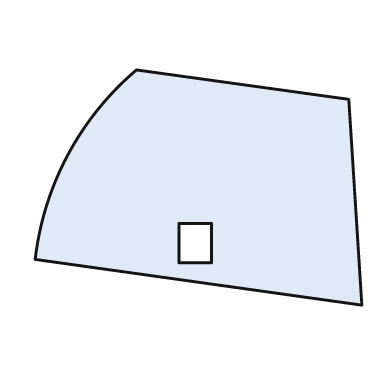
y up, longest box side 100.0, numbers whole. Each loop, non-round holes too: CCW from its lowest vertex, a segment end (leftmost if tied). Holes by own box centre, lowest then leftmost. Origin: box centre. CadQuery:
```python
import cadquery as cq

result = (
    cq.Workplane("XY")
    .moveTo(50.0, -36.0)
    .lineTo(46.0, 27.0)
    .lineTo(-19.0, 36.0)
    .threePointArc((-40.0, 10.0), (-50.0, -22.0))
    .close()
    .moveTo(-6.0, -23.0)
    .lineTo(4.0, -23.0)
    .lineTo(4.0, -11.0)
    .lineTo(-6.0, -11.0)
    .close()
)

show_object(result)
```